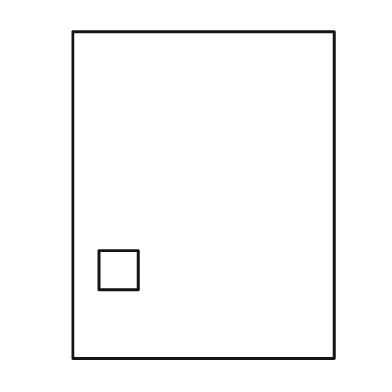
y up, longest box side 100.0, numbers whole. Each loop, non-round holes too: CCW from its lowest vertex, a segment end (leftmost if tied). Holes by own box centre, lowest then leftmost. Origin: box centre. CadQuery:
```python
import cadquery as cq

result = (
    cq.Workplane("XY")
    .moveTo(-40.0, -50.0)
    .lineTo(40.0, -50.0)
    .lineTo(40.0, 50.0)
    .lineTo(-40.0, 50.0)
    .close()
    .moveTo(-32.0, -29.0)
    .lineTo(-20.0, -29.0)
    .lineTo(-20.0, -17.0)
    .lineTo(-32.0, -17.0)
    .close()
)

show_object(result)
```